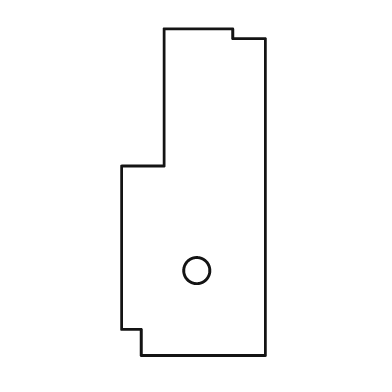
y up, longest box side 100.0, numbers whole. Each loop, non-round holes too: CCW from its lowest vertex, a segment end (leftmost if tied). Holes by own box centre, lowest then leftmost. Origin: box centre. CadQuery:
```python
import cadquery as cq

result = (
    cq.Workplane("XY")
    .moveTo(-16.0, -50.0)
    .lineTo(22.0, -50.0)
    .lineTo(22.0, 47.0)
    .lineTo(12.0, 47.0)
    .lineTo(12.0, 50.0)
    .lineTo(-9.0, 50.0)
    .lineTo(-9.0, 8.0)
    .lineTo(-22.0, 8.0)
    .lineTo(-22.0, -42.0)
    .lineTo(-16.0, -42.0)
    .close()
    .moveTo(1.0, -24.0)
    .circle(4.0)
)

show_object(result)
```